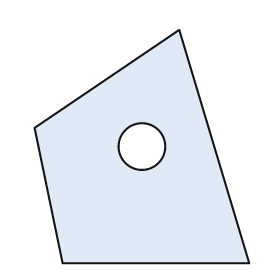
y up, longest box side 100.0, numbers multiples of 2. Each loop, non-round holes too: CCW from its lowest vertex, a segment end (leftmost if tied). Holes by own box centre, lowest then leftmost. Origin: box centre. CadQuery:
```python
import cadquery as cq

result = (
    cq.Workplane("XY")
    .moveTo(-34.0, -50.0)
    .lineTo(46.0, -50.0)
    .lineTo(16.0, 50.0)
    .lineTo(-46.0, 8.0)
    .close()
    .moveTo(0.0, 0.0)
    .circle(10.0)
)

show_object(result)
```